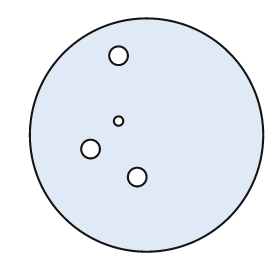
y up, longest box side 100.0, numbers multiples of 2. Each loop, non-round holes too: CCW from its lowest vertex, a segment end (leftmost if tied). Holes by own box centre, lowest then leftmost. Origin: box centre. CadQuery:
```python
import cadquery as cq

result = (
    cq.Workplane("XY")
    .moveTo(0.0, 0.0)
    .circle(50.0)
    .moveTo(-4.0, -18.0)
    .circle(4.0)
    .moveTo(-24.0, -6.0)
    .circle(4.0)
    .moveTo(-12.0, 6.0)
    .circle(2.0)
    .moveTo(-12.0, 34.0)
    .circle(4.0)
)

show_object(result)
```